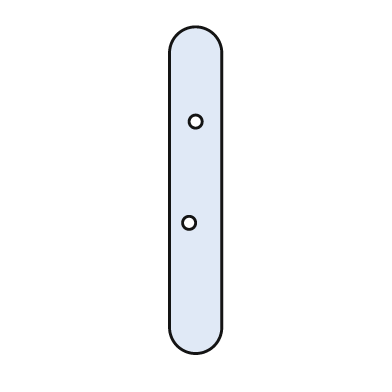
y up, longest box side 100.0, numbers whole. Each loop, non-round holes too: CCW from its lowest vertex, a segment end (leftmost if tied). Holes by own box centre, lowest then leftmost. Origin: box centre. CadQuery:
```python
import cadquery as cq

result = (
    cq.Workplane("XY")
    .moveTo(-8.0, -42.0)
    .threePointArc((0.0, -50.0), (8.0, -42.0))
    .lineTo(8.0, 42.0)
    .threePointArc((0.0, 50.0), (-8.0, 42.0))
    .close()
    .moveTo(-2.0, -10.0)
    .circle(2.0)
    .moveTo(0.0, 21.0)
    .circle(2.0)
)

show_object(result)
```